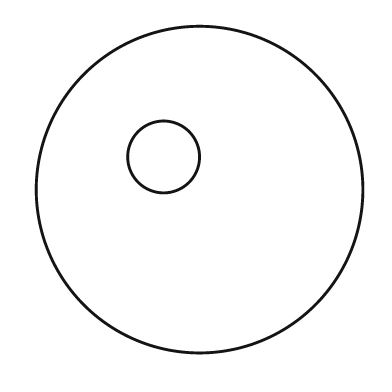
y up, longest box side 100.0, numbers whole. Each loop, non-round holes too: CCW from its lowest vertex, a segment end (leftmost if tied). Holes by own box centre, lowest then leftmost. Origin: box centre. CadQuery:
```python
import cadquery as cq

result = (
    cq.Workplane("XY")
    .moveTo(0.0, 0.0)
    .circle(50.0)
    .moveTo(-11.0, 10.0)
    .circle(11.0)
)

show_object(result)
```